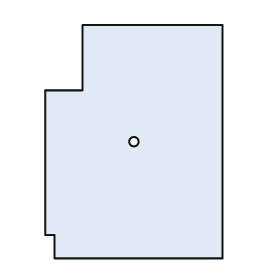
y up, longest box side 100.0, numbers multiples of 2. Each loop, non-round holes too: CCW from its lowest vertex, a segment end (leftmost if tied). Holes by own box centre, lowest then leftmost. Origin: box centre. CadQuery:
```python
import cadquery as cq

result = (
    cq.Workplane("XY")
    .moveTo(-34.0, -50.0)
    .lineTo(38.0, -50.0)
    .lineTo(38.0, 50.0)
    .lineTo(-22.0, 50.0)
    .lineTo(-22.0, 22.0)
    .lineTo(-38.0, 22.0)
    .lineTo(-38.0, -40.0)
    .lineTo(-34.0, -40.0)
    .close()
    .moveTo(0.0, 0.0)
    .circle(2.0)
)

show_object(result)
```